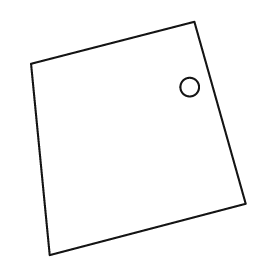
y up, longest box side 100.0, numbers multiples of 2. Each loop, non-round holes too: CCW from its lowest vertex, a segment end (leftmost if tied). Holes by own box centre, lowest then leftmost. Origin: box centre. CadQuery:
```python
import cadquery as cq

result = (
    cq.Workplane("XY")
    .moveTo(-38.0, -50.0)
    .lineTo(46.0, -28.0)
    .lineTo(24.0, 50.0)
    .lineTo(-46.0, 32.0)
    .close()
    .moveTo(22.0, 22.0)
    .circle(4.0)
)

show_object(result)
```